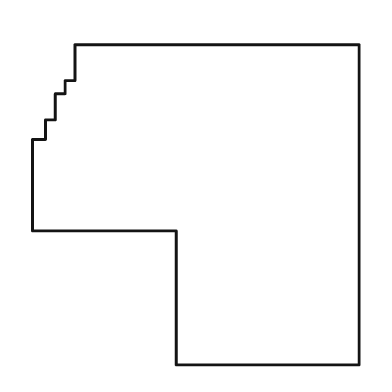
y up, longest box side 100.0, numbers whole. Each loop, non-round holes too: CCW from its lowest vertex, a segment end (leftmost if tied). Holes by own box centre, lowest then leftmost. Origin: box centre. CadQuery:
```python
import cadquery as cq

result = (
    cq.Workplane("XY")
    .moveTo(-6.0, -49.0)
    .lineTo(50.0, -49.0)
    .lineTo(50.0, 49.0)
    .lineTo(-37.0, 49.0)
    .lineTo(-37.0, 38.0)
    .lineTo(-40.0, 38.0)
    .lineTo(-40.0, 34.0)
    .lineTo(-43.0, 34.0)
    .lineTo(-43.0, 26.0)
    .lineTo(-46.0, 26.0)
    .lineTo(-46.0, 20.0)
    .lineTo(-50.0, 20.0)
    .lineTo(-50.0, -8.0)
    .lineTo(-6.0, -8.0)
    .close()
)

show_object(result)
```